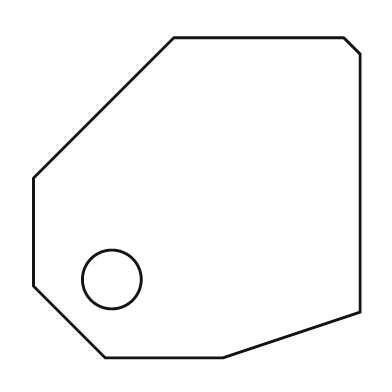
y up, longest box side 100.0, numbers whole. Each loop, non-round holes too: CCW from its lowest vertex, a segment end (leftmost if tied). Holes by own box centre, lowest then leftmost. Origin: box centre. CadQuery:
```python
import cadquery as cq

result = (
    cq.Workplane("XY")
    .moveTo(-28.0, -49.0)
    .lineTo(8.0, -49.0)
    .lineTo(50.0, -35.0)
    .lineTo(50.0, 44.0)
    .lineTo(45.0, 49.0)
    .lineTo(-7.0, 49.0)
    .lineTo(-50.0, 6.0)
    .lineTo(-50.0, -27.0)
    .close()
    .moveTo(-26.0, -25.0)
    .circle(9.0)
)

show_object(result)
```